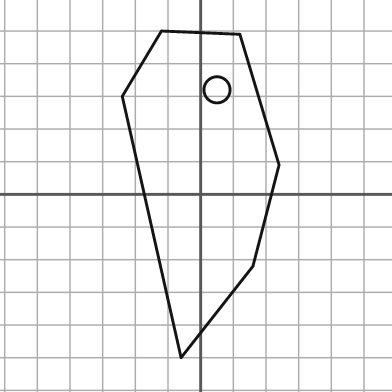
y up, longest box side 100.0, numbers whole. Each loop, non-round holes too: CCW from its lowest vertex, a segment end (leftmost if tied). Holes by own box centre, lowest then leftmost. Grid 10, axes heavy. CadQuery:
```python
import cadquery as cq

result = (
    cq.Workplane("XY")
    .moveTo(-6.0, -50.0)
    .lineTo(16.0, -22.0)
    .lineTo(24.0, 9.0)
    .lineTo(12.0, 49.0)
    .lineTo(-12.0, 50.0)
    .lineTo(-24.0, 30.0)
    .close()
    .moveTo(5.0, 32.0)
    .circle(4.0)
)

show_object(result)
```